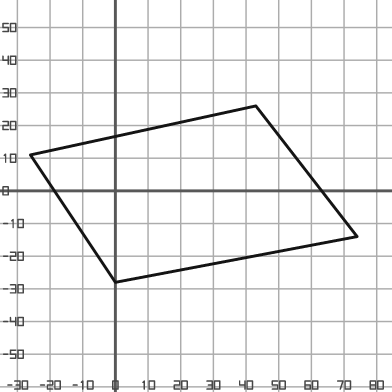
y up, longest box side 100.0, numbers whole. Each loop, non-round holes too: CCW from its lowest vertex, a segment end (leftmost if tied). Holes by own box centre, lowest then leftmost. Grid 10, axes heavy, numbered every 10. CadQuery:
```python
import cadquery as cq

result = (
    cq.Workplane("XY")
    .moveTo(0.0, -28.0)
    .lineTo(74.0, -14.0)
    .lineTo(43.0, 26.0)
    .lineTo(-26.0, 11.0)
    .close()
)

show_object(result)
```